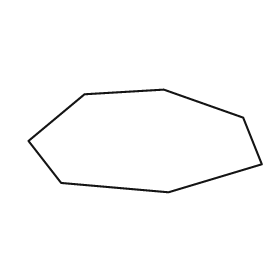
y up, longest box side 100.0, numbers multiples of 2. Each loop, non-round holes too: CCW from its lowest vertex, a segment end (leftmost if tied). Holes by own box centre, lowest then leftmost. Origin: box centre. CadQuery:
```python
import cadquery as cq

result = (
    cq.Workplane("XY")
    .moveTo(10.0, -22.0)
    .lineTo(50.0, -10.0)
    .lineTo(42.0, 10.0)
    .lineTo(8.0, 22.0)
    .lineTo(-26.0, 20.0)
    .lineTo(-50.0, 0.0)
    .lineTo(-36.0, -18.0)
    .close()
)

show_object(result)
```